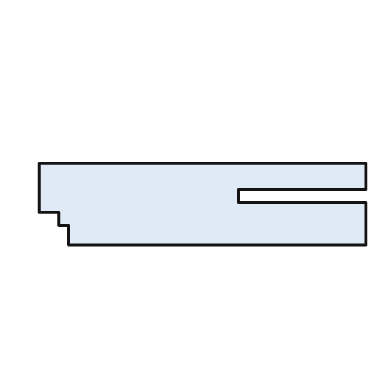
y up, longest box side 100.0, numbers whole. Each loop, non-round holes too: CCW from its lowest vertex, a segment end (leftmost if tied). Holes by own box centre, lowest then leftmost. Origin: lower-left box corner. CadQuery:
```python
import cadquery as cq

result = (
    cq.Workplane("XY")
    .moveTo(9.0, 0.0)
    .lineTo(100.0, 0.0)
    .lineTo(100.0, 13.0)
    .lineTo(61.0, 13.0)
    .lineTo(61.0, 17.0)
    .lineTo(100.0, 17.0)
    .lineTo(100.0, 25.0)
    .lineTo(0.0, 25.0)
    .lineTo(0.0, 10.0)
    .lineTo(6.0, 10.0)
    .lineTo(6.0, 6.0)
    .lineTo(9.0, 6.0)
    .close()
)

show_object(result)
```